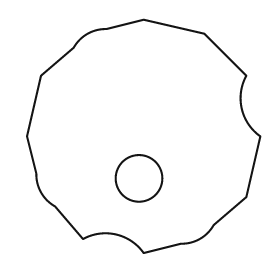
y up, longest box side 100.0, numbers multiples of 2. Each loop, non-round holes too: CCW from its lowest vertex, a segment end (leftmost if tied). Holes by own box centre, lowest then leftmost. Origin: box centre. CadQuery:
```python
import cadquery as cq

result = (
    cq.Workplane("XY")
    .moveTo(0.0, -50.0)
    .lineTo(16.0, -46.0)
    .threePointArc((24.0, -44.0), (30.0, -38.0))
    .lineTo(44.0, -26.0)
    .lineTo(50.0, 0.0)
    .threePointArc((42.0, 12.0), (44.0, 26.0))
    .lineTo(26.0, 44.0)
    .lineTo(0.0, 50.0)
    .lineTo(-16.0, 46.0)
    .threePointArc((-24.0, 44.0), (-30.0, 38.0))
    .lineTo(-44.0, 26.0)
    .lineTo(-50.0, 0.0)
    .lineTo(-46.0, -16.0)
    .threePointArc((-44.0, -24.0), (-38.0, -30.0))
    .lineTo(-26.0, -44.0)
    .threePointArc((-12.0, -42.0), (0.0, -50.0))
    .close()
    .moveTo(-2.0, -18.0)
    .circle(10.0)
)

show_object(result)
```